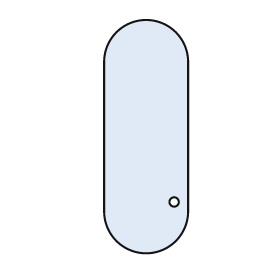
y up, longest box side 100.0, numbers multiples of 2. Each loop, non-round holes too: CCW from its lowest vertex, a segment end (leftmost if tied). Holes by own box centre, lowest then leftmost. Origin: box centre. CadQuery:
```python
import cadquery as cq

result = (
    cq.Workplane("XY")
    .moveTo(-18.0, -32.0)
    .threePointArc((0.0, -50.0), (18.0, -32.0))
    .lineTo(18.0, 32.0)
    .threePointArc((0.0, 50.0), (-18.0, 32.0))
    .close()
    .moveTo(12.0, -28.0)
    .circle(2.0)
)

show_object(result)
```